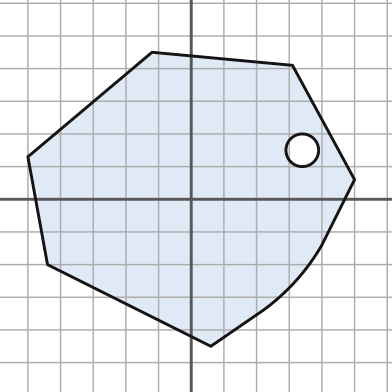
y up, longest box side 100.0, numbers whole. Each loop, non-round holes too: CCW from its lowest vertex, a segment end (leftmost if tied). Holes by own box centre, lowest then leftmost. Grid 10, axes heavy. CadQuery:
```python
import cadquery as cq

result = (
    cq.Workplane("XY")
    .moveTo(6.0, -45.0)
    .lineTo(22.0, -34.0)
    .threePointArc((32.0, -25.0), (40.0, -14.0))
    .lineTo(50.0, 6.0)
    .lineTo(31.0, 41.0)
    .lineTo(-12.0, 45.0)
    .lineTo(-50.0, 13.0)
    .lineTo(-44.0, -20.0)
    .close()
    .moveTo(34.0, 15.0)
    .circle(5.0)
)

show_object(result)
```